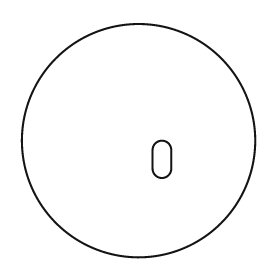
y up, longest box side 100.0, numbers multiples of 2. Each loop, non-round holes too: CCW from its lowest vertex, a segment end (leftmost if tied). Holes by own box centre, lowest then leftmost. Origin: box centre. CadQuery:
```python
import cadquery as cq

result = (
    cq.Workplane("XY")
    .moveTo(0.0, 0.0)
    .circle(50.0)
    .moveTo(6.0, -12.0)
    .threePointArc((10.0, -16.0), (14.0, -12.0))
    .lineTo(14.0, -4.0)
    .threePointArc((10.0, 0.0), (6.0, -4.0))
    .close()
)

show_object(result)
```